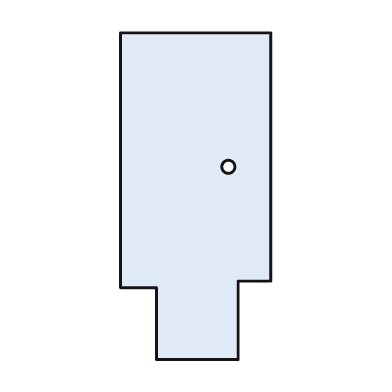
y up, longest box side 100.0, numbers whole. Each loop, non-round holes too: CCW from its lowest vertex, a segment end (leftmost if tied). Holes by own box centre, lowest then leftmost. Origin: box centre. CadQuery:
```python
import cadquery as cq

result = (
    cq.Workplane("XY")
    .moveTo(-12.0, -50.0)
    .lineTo(13.0, -50.0)
    .lineTo(13.0, -26.0)
    .lineTo(23.0, -26.0)
    .lineTo(23.0, 50.0)
    .lineTo(-23.0, 50.0)
    .lineTo(-23.0, -28.0)
    .lineTo(-12.0, -28.0)
    .close()
    .moveTo(10.0, 9.0)
    .circle(2.0)
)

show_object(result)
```